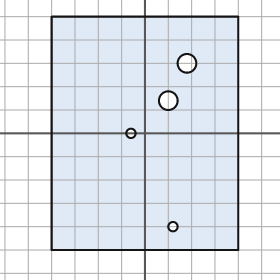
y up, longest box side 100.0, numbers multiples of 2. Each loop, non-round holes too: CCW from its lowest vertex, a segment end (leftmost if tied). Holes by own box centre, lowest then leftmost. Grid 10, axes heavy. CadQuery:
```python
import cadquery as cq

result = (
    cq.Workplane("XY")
    .moveTo(-40.0, -50.0)
    .lineTo(40.0, -50.0)
    .lineTo(40.0, 50.0)
    .lineTo(-40.0, 50.0)
    .close()
    .moveTo(12.0, -40.0)
    .circle(2.0)
    .moveTo(-6.0, 0.0)
    .circle(2.0)
    .moveTo(10.0, 14.0)
    .circle(4.0)
    .moveTo(18.0, 30.0)
    .circle(4.0)
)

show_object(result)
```